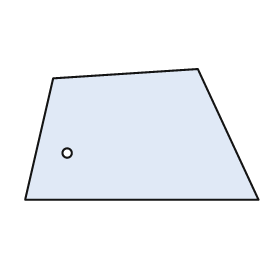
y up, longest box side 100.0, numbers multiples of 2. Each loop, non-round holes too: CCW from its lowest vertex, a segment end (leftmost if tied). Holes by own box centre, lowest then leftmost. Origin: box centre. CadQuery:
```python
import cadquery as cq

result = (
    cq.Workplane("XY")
    .moveTo(-50.0, -28.0)
    .lineTo(50.0, -28.0)
    .lineTo(24.0, 28.0)
    .lineTo(-38.0, 24.0)
    .close()
    .moveTo(-32.0, -8.0)
    .circle(2.0)
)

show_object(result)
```